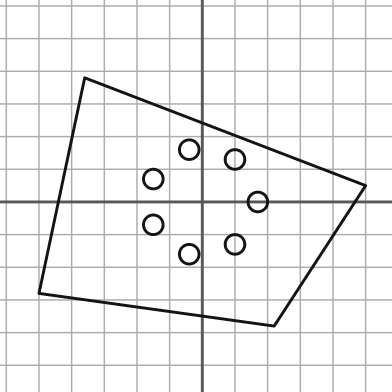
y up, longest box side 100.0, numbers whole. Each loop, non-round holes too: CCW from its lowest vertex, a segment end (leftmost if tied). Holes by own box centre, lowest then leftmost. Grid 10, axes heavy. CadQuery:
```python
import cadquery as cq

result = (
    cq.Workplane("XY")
    .moveTo(22.0, -38.0)
    .lineTo(50.0, 5.0)
    .lineTo(-36.0, 38.0)
    .lineTo(-50.0, -28.0)
    .close()
    .moveTo(-4.0, -16.0)
    .circle(3.0)
    .moveTo(10.0, -13.0)
    .circle(3.0)
    .moveTo(-15.0, -7.0)
    .circle(3.0)
    .moveTo(17.0, 0.0)
    .circle(3.0)
    .moveTo(-15.0, 7.0)
    .circle(3.0)
    .moveTo(10.0, 13.0)
    .circle(3.0)
    .moveTo(-4.0, 16.0)
    .circle(3.0)
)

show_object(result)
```